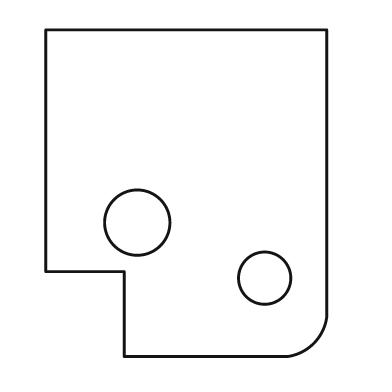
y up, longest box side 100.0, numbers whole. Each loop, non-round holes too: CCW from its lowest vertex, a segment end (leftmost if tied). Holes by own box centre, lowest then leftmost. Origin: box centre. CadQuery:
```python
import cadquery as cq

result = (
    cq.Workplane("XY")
    .moveTo(-19.0, -50.0)
    .lineTo(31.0, -50.0)
    .threePointArc((39.0, -46.0), (43.0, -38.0))
    .lineTo(43.0, 50.0)
    .lineTo(-43.0, 50.0)
    .lineTo(-43.0, -24.0)
    .lineTo(-19.0, -24.0)
    .close()
    .moveTo(24.0, -26.0)
    .circle(8.0)
    .moveTo(-15.0, -9.0)
    .circle(10.0)
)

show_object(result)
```